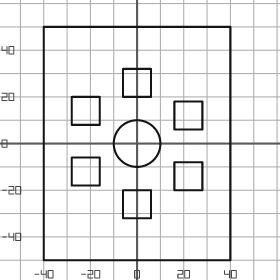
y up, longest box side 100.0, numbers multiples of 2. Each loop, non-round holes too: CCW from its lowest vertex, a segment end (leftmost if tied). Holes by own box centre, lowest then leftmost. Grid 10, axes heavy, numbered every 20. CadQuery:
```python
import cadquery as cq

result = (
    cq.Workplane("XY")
    .moveTo(-40.0, -50.0)
    .lineTo(40.0, -50.0)
    .lineTo(40.0, 50.0)
    .lineTo(-40.0, 50.0)
    .close()
    .moveTo(-6.0, -32.0)
    .lineTo(6.0, -32.0)
    .lineTo(6.0, -20.0)
    .lineTo(-6.0, -20.0)
    .close()
    .moveTo(16.0, -20.0)
    .lineTo(28.0, -20.0)
    .lineTo(28.0, -8.0)
    .lineTo(16.0, -8.0)
    .close()
    .moveTo(-28.0, -18.0)
    .lineTo(-16.0, -18.0)
    .lineTo(-16.0, -6.0)
    .lineTo(-28.0, -6.0)
    .close()
    .moveTo(0.0, 0.0)
    .circle(10.0)
    .moveTo(16.0, 6.0)
    .lineTo(28.0, 6.0)
    .lineTo(28.0, 18.0)
    .lineTo(16.0, 18.0)
    .close()
    .moveTo(-28.0, 8.0)
    .lineTo(-16.0, 8.0)
    .lineTo(-16.0, 20.0)
    .lineTo(-28.0, 20.0)
    .close()
    .moveTo(-6.0, 20.0)
    .lineTo(6.0, 20.0)
    .lineTo(6.0, 32.0)
    .lineTo(-6.0, 32.0)
    .close()
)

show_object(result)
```